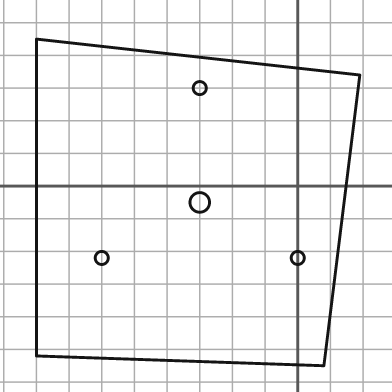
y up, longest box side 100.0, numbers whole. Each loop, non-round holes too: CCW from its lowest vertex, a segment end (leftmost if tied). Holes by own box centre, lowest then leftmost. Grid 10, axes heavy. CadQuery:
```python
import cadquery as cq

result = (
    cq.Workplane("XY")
    .moveTo(8.0, -55.0)
    .lineTo(19.0, 34.0)
    .lineTo(-80.0, 45.0)
    .lineTo(-80.0, -52.0)
    .close()
    .moveTo(-60.0, -22.0)
    .circle(2.0)
    .moveTo(0.0, -22.0)
    .circle(2.0)
    .moveTo(-30.0, -5.0)
    .circle(3.0)
    .moveTo(-30.0, 30.0)
    .circle(2.0)
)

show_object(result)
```